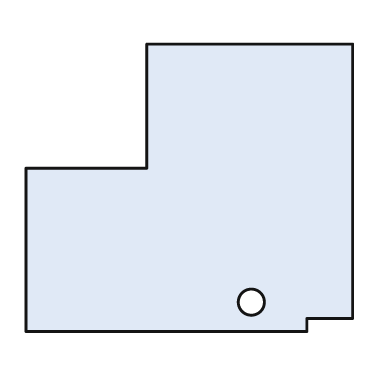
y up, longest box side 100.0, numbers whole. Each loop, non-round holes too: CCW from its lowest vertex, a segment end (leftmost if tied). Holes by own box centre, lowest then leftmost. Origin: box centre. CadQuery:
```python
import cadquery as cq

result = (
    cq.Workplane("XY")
    .moveTo(-50.0, -44.0)
    .lineTo(36.0, -44.0)
    .lineTo(36.0, -40.0)
    .lineTo(50.0, -40.0)
    .lineTo(50.0, 44.0)
    .lineTo(-13.0, 44.0)
    .lineTo(-13.0, 6.0)
    .lineTo(-50.0, 6.0)
    .close()
    .moveTo(19.0, -35.0)
    .circle(4.0)
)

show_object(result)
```